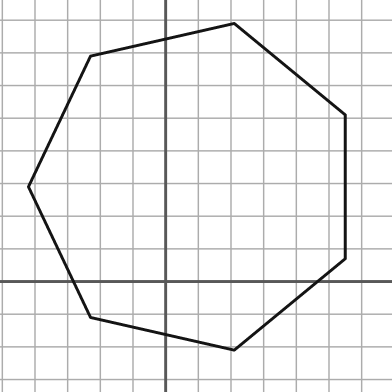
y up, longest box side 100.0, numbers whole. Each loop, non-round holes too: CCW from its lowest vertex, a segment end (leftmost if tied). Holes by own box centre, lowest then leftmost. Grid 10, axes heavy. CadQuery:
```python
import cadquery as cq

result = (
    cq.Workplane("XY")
    .moveTo(21.0, -21.0)
    .lineTo(55.0, 7.0)
    .lineTo(55.0, 51.0)
    .lineTo(21.0, 79.0)
    .lineTo(-23.0, 69.0)
    .lineTo(-42.0, 29.0)
    .lineTo(-23.0, -11.0)
    .close()
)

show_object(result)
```